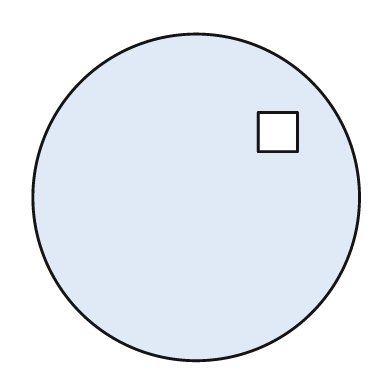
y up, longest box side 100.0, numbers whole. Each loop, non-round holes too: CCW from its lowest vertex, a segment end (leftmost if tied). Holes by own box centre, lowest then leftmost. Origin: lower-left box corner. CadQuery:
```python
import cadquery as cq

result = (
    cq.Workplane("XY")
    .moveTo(50.0, 50.0)
    .circle(50.0)
    .moveTo(69.0, 64.0)
    .lineTo(81.0, 64.0)
    .lineTo(81.0, 76.0)
    .lineTo(69.0, 76.0)
    .close()
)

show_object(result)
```